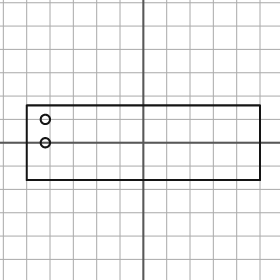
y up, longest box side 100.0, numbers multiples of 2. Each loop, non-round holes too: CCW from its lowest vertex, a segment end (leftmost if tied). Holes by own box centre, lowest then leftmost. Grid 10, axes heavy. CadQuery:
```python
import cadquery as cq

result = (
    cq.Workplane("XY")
    .moveTo(-50.0, -16.0)
    .lineTo(50.0, -16.0)
    .lineTo(50.0, 16.0)
    .lineTo(-50.0, 16.0)
    .close()
    .moveTo(-42.0, 0.0)
    .circle(2.0)
    .moveTo(-42.0, 10.0)
    .circle(2.0)
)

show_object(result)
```